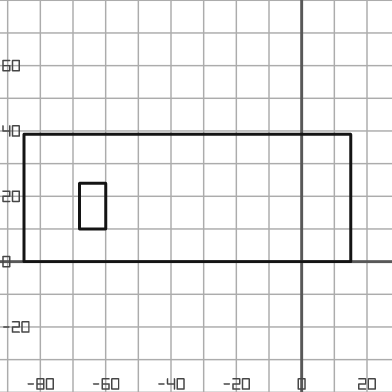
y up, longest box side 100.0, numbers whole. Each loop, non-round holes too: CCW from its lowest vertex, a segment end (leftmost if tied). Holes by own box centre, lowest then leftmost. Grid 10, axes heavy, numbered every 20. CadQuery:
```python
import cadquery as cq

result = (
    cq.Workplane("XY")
    .moveTo(-85.0, 0.0)
    .lineTo(15.0, 0.0)
    .lineTo(15.0, 39.0)
    .lineTo(-85.0, 39.0)
    .close()
    .moveTo(-68.0, 10.0)
    .lineTo(-60.0, 10.0)
    .lineTo(-60.0, 24.0)
    .lineTo(-68.0, 24.0)
    .close()
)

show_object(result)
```